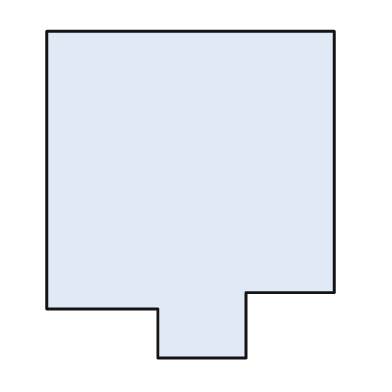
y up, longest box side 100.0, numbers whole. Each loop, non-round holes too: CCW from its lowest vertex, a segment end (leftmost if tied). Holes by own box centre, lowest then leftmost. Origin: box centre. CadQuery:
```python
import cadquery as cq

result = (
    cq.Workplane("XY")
    .moveTo(-10.0, -50.0)
    .lineTo(17.0, -50.0)
    .lineTo(17.0, -30.0)
    .lineTo(44.0, -30.0)
    .lineTo(44.0, 50.0)
    .lineTo(-44.0, 50.0)
    .lineTo(-44.0, -35.0)
    .lineTo(-10.0, -35.0)
    .close()
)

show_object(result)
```